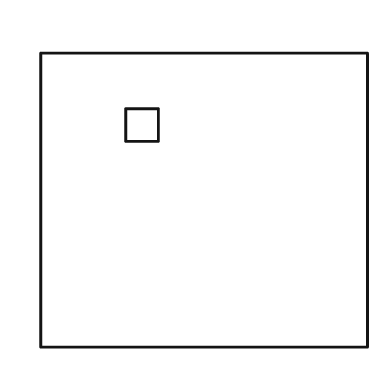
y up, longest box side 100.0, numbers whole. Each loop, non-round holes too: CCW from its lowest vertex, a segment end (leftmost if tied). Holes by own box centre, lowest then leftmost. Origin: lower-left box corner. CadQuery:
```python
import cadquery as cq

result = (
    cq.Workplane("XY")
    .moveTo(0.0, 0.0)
    .lineTo(100.0, 0.0)
    .lineTo(100.0, 90.0)
    .lineTo(0.0, 90.0)
    .close()
    .moveTo(26.0, 63.0)
    .lineTo(36.0, 63.0)
    .lineTo(36.0, 73.0)
    .lineTo(26.0, 73.0)
    .close()
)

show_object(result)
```